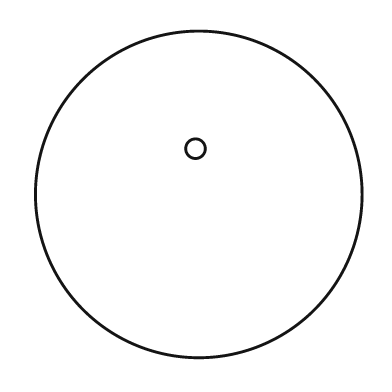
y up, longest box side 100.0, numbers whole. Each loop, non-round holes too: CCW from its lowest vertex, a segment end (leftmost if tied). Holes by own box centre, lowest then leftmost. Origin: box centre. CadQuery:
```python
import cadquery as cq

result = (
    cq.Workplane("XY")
    .moveTo(0.0, 0.0)
    .circle(50.0)
    .moveTo(-1.0, 14.0)
    .circle(3.0)
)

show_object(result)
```